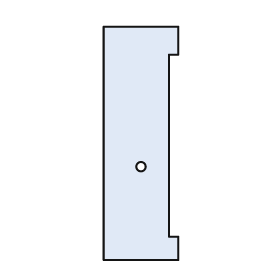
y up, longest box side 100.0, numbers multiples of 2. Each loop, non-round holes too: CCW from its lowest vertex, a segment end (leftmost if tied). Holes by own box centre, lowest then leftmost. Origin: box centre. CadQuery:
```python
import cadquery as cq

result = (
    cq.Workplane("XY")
    .moveTo(-16.0, -50.0)
    .lineTo(16.0, -50.0)
    .lineTo(16.0, -40.0)
    .lineTo(12.0, -40.0)
    .lineTo(12.0, 38.0)
    .lineTo(16.0, 38.0)
    .lineTo(16.0, 50.0)
    .lineTo(-16.0, 50.0)
    .close()
    .moveTo(0.0, -10.0)
    .circle(2.0)
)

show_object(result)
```